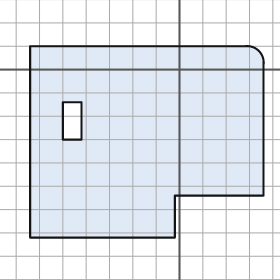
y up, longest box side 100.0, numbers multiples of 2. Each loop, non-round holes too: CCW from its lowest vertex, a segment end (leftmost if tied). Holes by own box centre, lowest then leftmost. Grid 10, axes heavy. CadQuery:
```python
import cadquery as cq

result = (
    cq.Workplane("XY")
    .moveTo(-64.0, -72.0)
    .lineTo(-2.0, -72.0)
    .lineTo(-2.0, -54.0)
    .lineTo(36.0, -54.0)
    .lineTo(36.0, 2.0)
    .threePointArc((34.0, 8.0), (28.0, 10.0))
    .lineTo(-64.0, 10.0)
    .close()
    .moveTo(-50.0, -30.0)
    .lineTo(-42.0, -30.0)
    .lineTo(-42.0, -14.0)
    .lineTo(-50.0, -14.0)
    .close()
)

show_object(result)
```